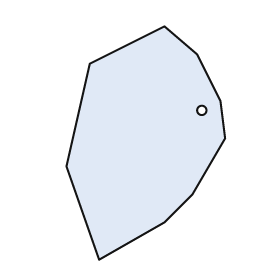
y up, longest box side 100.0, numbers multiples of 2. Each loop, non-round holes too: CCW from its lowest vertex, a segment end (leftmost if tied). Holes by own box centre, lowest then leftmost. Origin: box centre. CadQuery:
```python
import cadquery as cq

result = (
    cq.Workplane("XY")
    .moveTo(-20.0, -50.0)
    .lineTo(8.0, -34.0)
    .lineTo(20.0, -22.0)
    .lineTo(34.0, 2.0)
    .lineTo(32.0, 18.0)
    .lineTo(22.0, 38.0)
    .lineTo(8.0, 50.0)
    .lineTo(-24.0, 34.0)
    .lineTo(-34.0, -10.0)
    .close()
    .moveTo(24.0, 14.0)
    .circle(2.0)
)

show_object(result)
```